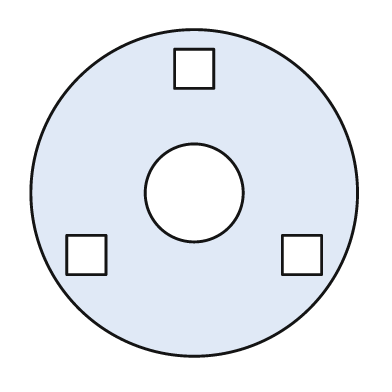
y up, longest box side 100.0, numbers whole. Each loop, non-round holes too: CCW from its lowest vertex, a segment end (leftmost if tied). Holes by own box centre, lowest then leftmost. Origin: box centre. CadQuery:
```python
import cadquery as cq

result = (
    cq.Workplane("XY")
    .moveTo(0.0, 0.0)
    .circle(50.0)
    .moveTo(-39.0, -25.0)
    .lineTo(-27.0, -25.0)
    .lineTo(-27.0, -13.0)
    .lineTo(-39.0, -13.0)
    .close()
    .moveTo(27.0, -25.0)
    .lineTo(39.0, -25.0)
    .lineTo(39.0, -13.0)
    .lineTo(27.0, -13.0)
    .close()
    .moveTo(0.0, 0.0)
    .circle(15.0)
    .moveTo(-6.0, 32.0)
    .lineTo(6.0, 32.0)
    .lineTo(6.0, 44.0)
    .lineTo(-6.0, 44.0)
    .close()
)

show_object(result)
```